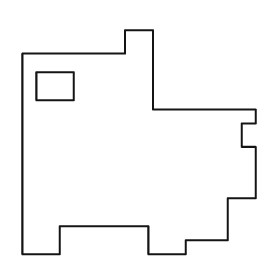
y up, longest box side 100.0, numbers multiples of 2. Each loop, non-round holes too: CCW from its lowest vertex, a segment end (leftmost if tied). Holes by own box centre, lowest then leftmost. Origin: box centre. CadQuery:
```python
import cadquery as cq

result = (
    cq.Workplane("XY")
    .moveTo(-50.0, -48.0)
    .lineTo(-34.0, -48.0)
    .lineTo(-34.0, -36.0)
    .lineTo(4.0, -36.0)
    .lineTo(4.0, -48.0)
    .lineTo(20.0, -48.0)
    .lineTo(20.0, -42.0)
    .lineTo(38.0, -42.0)
    .lineTo(38.0, -24.0)
    .lineTo(50.0, -24.0)
    .lineTo(50.0, -2.0)
    .lineTo(44.0, -2.0)
    .lineTo(44.0, 8.0)
    .lineTo(50.0, 8.0)
    .lineTo(50.0, 14.0)
    .lineTo(6.0, 14.0)
    .lineTo(6.0, 48.0)
    .lineTo(-6.0, 48.0)
    .lineTo(-6.0, 38.0)
    .lineTo(-50.0, 38.0)
    .close()
    .moveTo(-44.0, 18.0)
    .lineTo(-28.0, 18.0)
    .lineTo(-28.0, 30.0)
    .lineTo(-44.0, 30.0)
    .close()
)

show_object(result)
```